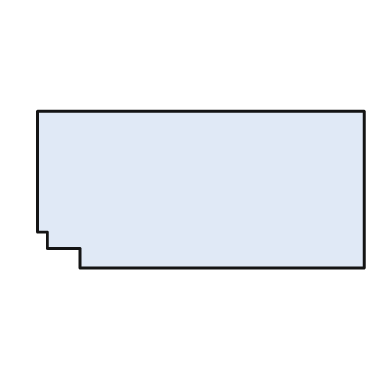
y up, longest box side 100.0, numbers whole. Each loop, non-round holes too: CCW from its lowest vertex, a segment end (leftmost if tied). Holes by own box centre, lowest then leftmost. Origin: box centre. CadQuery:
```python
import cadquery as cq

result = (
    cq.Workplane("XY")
    .moveTo(-37.0, -24.0)
    .lineTo(50.0, -24.0)
    .lineTo(50.0, 24.0)
    .lineTo(-50.0, 24.0)
    .lineTo(-50.0, -13.0)
    .lineTo(-47.0, -13.0)
    .lineTo(-47.0, -18.0)
    .lineTo(-37.0, -18.0)
    .close()
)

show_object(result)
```